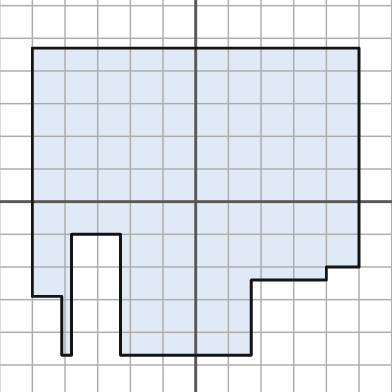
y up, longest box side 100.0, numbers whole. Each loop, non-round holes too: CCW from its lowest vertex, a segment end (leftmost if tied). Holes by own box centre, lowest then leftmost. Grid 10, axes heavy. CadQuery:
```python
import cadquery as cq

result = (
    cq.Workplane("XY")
    .moveTo(-41.0, -47.0)
    .lineTo(-38.0, -47.0)
    .lineTo(-38.0, -10.0)
    .lineTo(-23.0, -10.0)
    .lineTo(-23.0, -47.0)
    .lineTo(17.0, -47.0)
    .lineTo(17.0, -24.0)
    .lineTo(40.0, -24.0)
    .lineTo(40.0, -20.0)
    .lineTo(50.0, -20.0)
    .lineTo(50.0, 47.0)
    .lineTo(-50.0, 47.0)
    .lineTo(-50.0, -29.0)
    .lineTo(-41.0, -29.0)
    .close()
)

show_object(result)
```